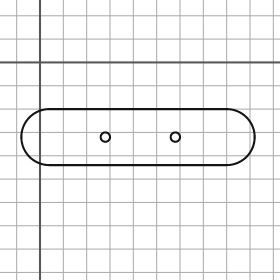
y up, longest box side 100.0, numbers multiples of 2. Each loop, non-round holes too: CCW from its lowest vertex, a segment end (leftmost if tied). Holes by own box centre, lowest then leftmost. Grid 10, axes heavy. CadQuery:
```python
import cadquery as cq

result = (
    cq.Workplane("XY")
    .moveTo(4.0, -44.0)
    .lineTo(80.0, -44.0)
    .threePointArc((92.0, -32.0), (80.0, -20.0))
    .lineTo(4.0, -20.0)
    .threePointArc((-8.0, -32.0), (4.0, -44.0))
    .close()
    .moveTo(28.0, -32.0)
    .circle(2.0)
    .moveTo(58.0, -32.0)
    .circle(2.0)
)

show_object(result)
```